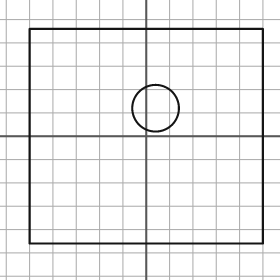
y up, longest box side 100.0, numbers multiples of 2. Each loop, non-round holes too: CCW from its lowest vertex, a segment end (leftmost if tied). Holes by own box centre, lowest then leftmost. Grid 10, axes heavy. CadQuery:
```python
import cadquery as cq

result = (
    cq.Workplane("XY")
    .moveTo(-50.0, -46.0)
    .lineTo(50.0, -46.0)
    .lineTo(50.0, 46.0)
    .lineTo(-50.0, 46.0)
    .close()
    .moveTo(4.0, 12.0)
    .circle(10.0)
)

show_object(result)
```